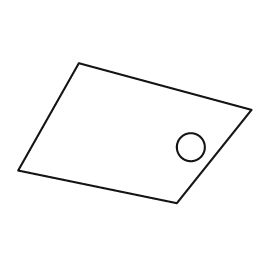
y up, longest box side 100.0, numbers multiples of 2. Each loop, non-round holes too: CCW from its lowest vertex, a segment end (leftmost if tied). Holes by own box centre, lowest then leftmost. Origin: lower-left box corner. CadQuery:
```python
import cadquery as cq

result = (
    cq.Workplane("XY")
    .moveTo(68.0, 0.0)
    .lineTo(100.0, 40.0)
    .lineTo(26.0, 60.0)
    .lineTo(0.0, 14.0)
    .close()
    .moveTo(74.0, 24.0)
    .circle(6.0)
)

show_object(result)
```